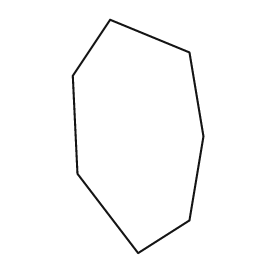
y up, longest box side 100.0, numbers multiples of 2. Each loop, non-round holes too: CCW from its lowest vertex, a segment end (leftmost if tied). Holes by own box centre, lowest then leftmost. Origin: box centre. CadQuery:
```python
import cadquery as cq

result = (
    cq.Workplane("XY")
    .moveTo(0.0, -50.0)
    .lineTo(22.0, -36.0)
    .lineTo(28.0, 0.0)
    .lineTo(22.0, 36.0)
    .lineTo(-12.0, 50.0)
    .lineTo(-28.0, 26.0)
    .lineTo(-26.0, -16.0)
    .close()
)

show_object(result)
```